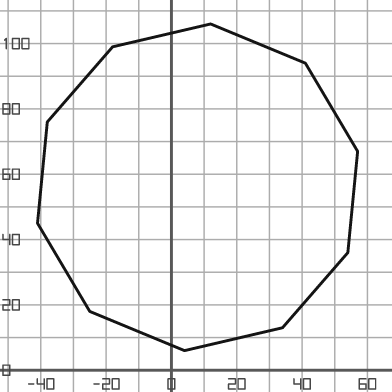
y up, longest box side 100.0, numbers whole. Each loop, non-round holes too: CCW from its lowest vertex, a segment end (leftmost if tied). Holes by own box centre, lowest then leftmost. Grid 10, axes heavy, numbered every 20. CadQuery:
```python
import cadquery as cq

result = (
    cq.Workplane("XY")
    .moveTo(4.0, 6.0)
    .lineTo(34.0, 13.0)
    .lineTo(54.0, 36.0)
    .lineTo(57.0, 67.0)
    .lineTo(41.0, 94.0)
    .lineTo(12.0, 106.0)
    .lineTo(-18.0, 99.0)
    .lineTo(-38.0, 76.0)
    .lineTo(-41.0, 45.0)
    .lineTo(-25.0, 18.0)
    .close()
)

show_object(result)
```